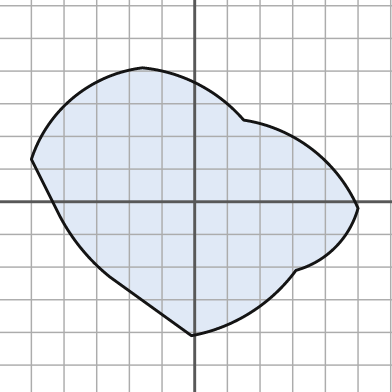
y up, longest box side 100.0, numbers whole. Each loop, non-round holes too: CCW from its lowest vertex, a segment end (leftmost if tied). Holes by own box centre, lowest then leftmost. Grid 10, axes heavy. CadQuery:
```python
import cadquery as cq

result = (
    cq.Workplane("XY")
    .moveTo(-1.0, -41.0)
    .threePointArc((17.0, -34.0), (31.0, -21.0))
    .threePointArc((43.0, -14.0), (50.0, -2.0))
    .threePointArc((36.0, 16.0), (15.0, 25.0))
    .threePointArc((1.0, 36.0), (-16.0, 41.0))
    .threePointArc((-37.0, 32.0), (-50.0, 13.0))
    .lineTo(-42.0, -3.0)
    .threePointArc((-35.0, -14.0), (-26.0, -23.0))
    .close()
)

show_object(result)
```